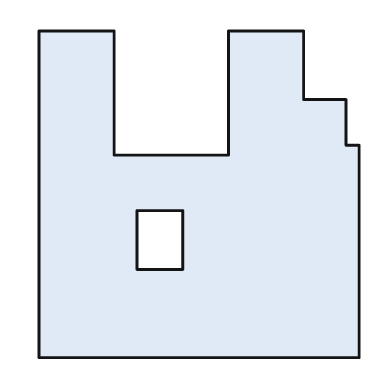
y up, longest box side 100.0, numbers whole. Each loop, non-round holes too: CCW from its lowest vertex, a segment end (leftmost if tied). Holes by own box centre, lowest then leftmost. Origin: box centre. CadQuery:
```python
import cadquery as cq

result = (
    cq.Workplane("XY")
    .moveTo(-49.0, -50.0)
    .lineTo(49.0, -50.0)
    .lineTo(49.0, 15.0)
    .lineTo(45.0, 15.0)
    .lineTo(45.0, 29.0)
    .lineTo(32.0, 29.0)
    .lineTo(32.0, 50.0)
    .lineTo(9.0, 50.0)
    .lineTo(9.0, 12.0)
    .lineTo(-26.0, 12.0)
    .lineTo(-26.0, 50.0)
    .lineTo(-49.0, 50.0)
    .close()
    .moveTo(-19.0, -23.0)
    .lineTo(-5.0, -23.0)
    .lineTo(-5.0, -5.0)
    .lineTo(-19.0, -5.0)
    .close()
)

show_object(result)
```